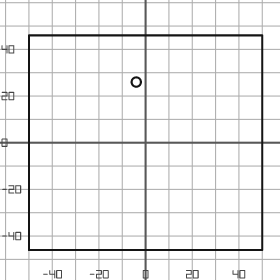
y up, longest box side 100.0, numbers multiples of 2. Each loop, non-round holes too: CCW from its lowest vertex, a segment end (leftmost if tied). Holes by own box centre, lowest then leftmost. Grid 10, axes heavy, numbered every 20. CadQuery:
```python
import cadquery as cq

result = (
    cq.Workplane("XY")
    .moveTo(-50.0, -46.0)
    .lineTo(50.0, -46.0)
    .lineTo(50.0, 46.0)
    .lineTo(-50.0, 46.0)
    .close()
    .moveTo(-4.0, 26.0)
    .circle(2.0)
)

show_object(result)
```